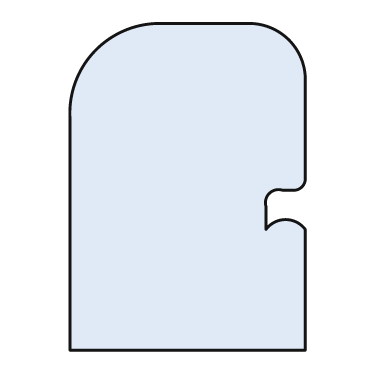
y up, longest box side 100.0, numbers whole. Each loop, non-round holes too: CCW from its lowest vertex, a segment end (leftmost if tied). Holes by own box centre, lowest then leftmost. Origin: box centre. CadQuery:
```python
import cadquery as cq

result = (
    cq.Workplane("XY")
    .moveTo(-36.0, -50.0)
    .lineTo(36.0, -50.0)
    .lineTo(36.0, -13.0)
    .threePointArc((30.0, -10.0), (24.0, -13.0))
    .lineTo(24.0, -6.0)
    .threePointArc((25.0, -2.0), (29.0, -1.0))
    .lineTo(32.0, -1.0)
    .threePointArc((35.0, 0.0), (36.0, 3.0))
    .lineTo(36.0, 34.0)
    .threePointArc((31.0, 45.0), (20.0, 50.0))
    .lineTo(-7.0, 50.0)
    .threePointArc((-28.0, 42.0), (-36.0, 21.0))
    .close()
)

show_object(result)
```